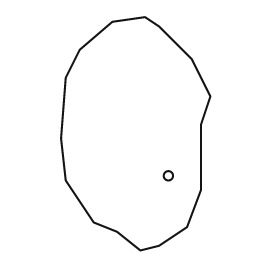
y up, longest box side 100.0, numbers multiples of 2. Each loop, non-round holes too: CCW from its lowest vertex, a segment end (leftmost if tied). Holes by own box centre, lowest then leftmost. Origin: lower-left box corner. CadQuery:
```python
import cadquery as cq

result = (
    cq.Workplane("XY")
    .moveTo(34.0, 0.0)
    .lineTo(42.0, 2.0)
    .lineTo(54.0, 10.0)
    .lineTo(60.0, 26.0)
    .lineTo(60.0, 54.0)
    .lineTo(64.0, 66.0)
    .lineTo(56.0, 82.0)
    .lineTo(42.0, 96.0)
    .lineTo(36.0, 100.0)
    .lineTo(22.0, 98.0)
    .lineTo(8.0, 86.0)
    .lineTo(2.0, 74.0)
    .lineTo(0.0, 48.0)
    .lineTo(2.0, 30.0)
    .lineTo(14.0, 12.0)
    .lineTo(24.0, 8.0)
    .close()
    .moveTo(46.0, 32.0)
    .circle(2.0)
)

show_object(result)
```